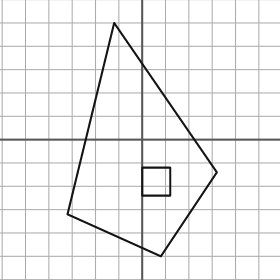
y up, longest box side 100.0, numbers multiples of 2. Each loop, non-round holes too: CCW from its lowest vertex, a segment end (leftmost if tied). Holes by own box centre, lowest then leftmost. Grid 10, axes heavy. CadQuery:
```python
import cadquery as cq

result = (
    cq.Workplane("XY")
    .moveTo(8.0, -50.0)
    .lineTo(32.0, -14.0)
    .lineTo(-12.0, 50.0)
    .lineTo(-32.0, -32.0)
    .close()
    .moveTo(0.0, -24.0)
    .lineTo(12.0, -24.0)
    .lineTo(12.0, -12.0)
    .lineTo(0.0, -12.0)
    .close()
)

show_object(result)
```